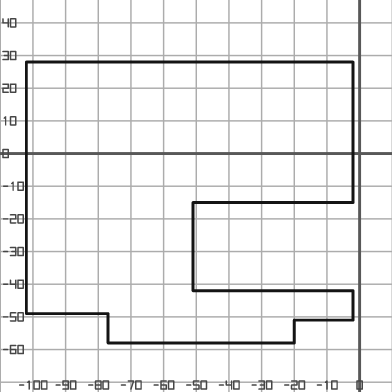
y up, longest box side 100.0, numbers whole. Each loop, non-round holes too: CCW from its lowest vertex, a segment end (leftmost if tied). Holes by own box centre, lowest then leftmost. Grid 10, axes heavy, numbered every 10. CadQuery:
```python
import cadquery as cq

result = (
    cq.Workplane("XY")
    .moveTo(-77.0, -58.0)
    .lineTo(-20.0, -58.0)
    .lineTo(-20.0, -51.0)
    .lineTo(-2.0, -51.0)
    .lineTo(-2.0, -42.0)
    .lineTo(-51.0, -42.0)
    .lineTo(-51.0, -15.0)
    .lineTo(-2.0, -15.0)
    .lineTo(-2.0, 28.0)
    .lineTo(-102.0, 28.0)
    .lineTo(-102.0, -49.0)
    .lineTo(-77.0, -49.0)
    .close()
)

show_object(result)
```